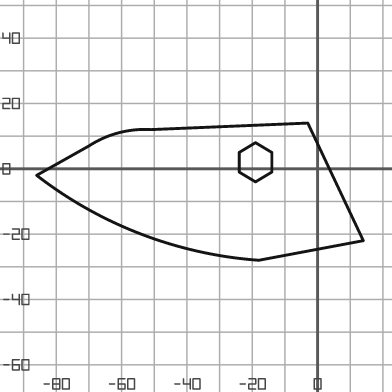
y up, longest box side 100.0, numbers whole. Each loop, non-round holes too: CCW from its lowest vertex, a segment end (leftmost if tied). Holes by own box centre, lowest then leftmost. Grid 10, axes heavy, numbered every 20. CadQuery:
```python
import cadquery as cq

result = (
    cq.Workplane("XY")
    .moveTo(-18.0, -28.0)
    .lineTo(14.0, -22.0)
    .lineTo(-3.0, 14.0)
    .lineTo(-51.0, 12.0)
    .threePointArc((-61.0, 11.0), (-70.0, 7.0))
    .lineTo(-86.0, -2.0)
    .threePointArc((-54.0, -20.0), (-18.0, -28.0))
    .close()
    .moveTo(-19.0, -4.0)
    .lineTo(-14.0, -1.0)
    .lineTo(-14.0, 5.0)
    .lineTo(-19.0, 8.0)
    .lineTo(-24.0, 5.0)
    .lineTo(-24.0, -1.0)
    .close()
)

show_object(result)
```